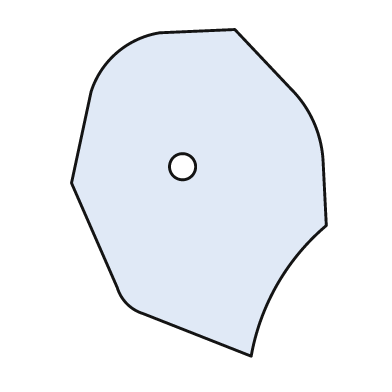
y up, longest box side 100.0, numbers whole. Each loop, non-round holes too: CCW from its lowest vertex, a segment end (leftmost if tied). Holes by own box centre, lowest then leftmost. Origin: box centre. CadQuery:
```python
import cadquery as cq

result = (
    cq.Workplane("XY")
    .moveTo(16.0, -50.0)
    .threePointArc((24.0, -28.0), (39.0, -10.0))
    .lineTo(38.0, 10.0)
    .threePointArc((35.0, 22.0), (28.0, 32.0))
    .lineTo(11.0, 50.0)
    .lineTo(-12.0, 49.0)
    .threePointArc((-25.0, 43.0), (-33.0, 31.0))
    .lineTo(-39.0, 3.0)
    .lineTo(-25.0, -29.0)
    .threePointArc((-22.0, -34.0), (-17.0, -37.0))
    .close()
    .moveTo(-5.0, 8.0)
    .circle(4.0)
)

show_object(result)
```